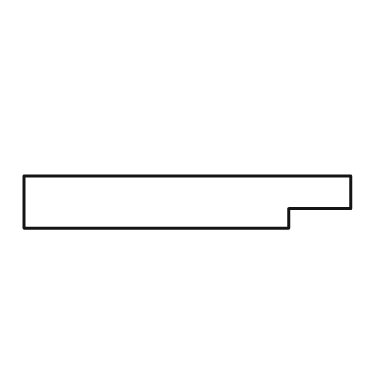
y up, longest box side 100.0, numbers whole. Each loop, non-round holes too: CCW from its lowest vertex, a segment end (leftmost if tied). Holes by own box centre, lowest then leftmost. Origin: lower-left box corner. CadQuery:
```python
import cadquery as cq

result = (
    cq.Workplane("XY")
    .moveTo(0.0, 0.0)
    .lineTo(81.0, 0.0)
    .lineTo(81.0, 6.0)
    .lineTo(100.0, 6.0)
    .lineTo(100.0, 16.0)
    .lineTo(0.0, 16.0)
    .close()
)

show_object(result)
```